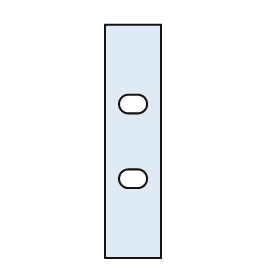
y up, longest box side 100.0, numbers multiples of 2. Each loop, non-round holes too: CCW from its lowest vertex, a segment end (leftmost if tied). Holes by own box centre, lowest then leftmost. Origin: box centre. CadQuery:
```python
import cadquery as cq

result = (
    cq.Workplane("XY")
    .moveTo(-12.0, -50.0)
    .lineTo(12.0, -50.0)
    .lineTo(12.0, 50.0)
    .lineTo(-12.0, 50.0)
    .close()
    .moveTo(-2.0, -20.0)
    .lineTo(2.0, -20.0)
    .threePointArc((6.0, -16.0), (2.0, -12.0))
    .lineTo(-2.0, -12.0)
    .threePointArc((-6.0, -16.0), (-2.0, -20.0))
    .close()
    .moveTo(-2.0, 12.0)
    .lineTo(2.0, 12.0)
    .threePointArc((6.0, 16.0), (2.0, 20.0))
    .lineTo(-2.0, 20.0)
    .threePointArc((-6.0, 16.0), (-2.0, 12.0))
    .close()
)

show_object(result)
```